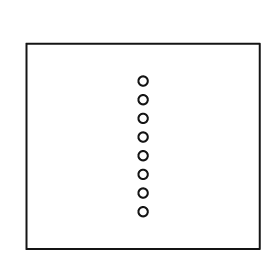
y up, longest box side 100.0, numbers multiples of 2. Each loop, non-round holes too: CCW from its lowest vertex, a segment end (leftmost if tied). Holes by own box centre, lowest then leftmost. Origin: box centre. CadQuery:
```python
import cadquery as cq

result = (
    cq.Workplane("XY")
    .moveTo(-50.0, -44.0)
    .lineTo(50.0, -44.0)
    .lineTo(50.0, 44.0)
    .lineTo(-50.0, 44.0)
    .close()
    .moveTo(0.0, -28.0)
    .circle(2.0)
    .moveTo(0.0, -20.0)
    .circle(2.0)
    .moveTo(0.0, -12.0)
    .circle(2.0)
    .moveTo(0.0, -4.0)
    .circle(2.0)
    .moveTo(0.0, 4.0)
    .circle(2.0)
    .moveTo(0.0, 12.0)
    .circle(2.0)
    .moveTo(0.0, 20.0)
    .circle(2.0)
    .moveTo(0.0, 28.0)
    .circle(2.0)
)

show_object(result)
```